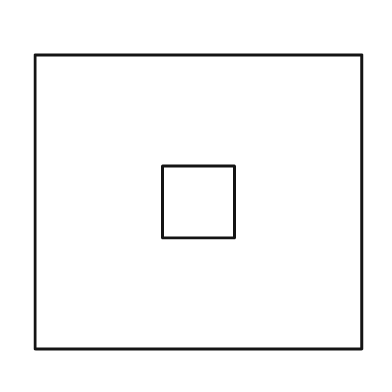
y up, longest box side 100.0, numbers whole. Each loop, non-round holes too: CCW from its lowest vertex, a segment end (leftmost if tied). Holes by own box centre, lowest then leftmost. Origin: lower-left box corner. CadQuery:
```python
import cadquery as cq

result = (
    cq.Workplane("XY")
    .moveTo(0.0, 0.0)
    .lineTo(100.0, 0.0)
    .lineTo(100.0, 90.0)
    .lineTo(0.0, 90.0)
    .close()
    .moveTo(39.0, 34.0)
    .lineTo(61.0, 34.0)
    .lineTo(61.0, 56.0)
    .lineTo(39.0, 56.0)
    .close()
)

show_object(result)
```